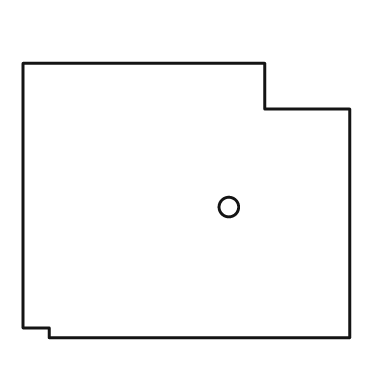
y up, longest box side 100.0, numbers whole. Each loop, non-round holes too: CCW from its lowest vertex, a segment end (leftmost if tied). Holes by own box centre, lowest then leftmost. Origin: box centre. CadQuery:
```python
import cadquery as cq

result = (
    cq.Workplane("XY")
    .moveTo(-42.0, -42.0)
    .lineTo(50.0, -42.0)
    .lineTo(50.0, 28.0)
    .lineTo(24.0, 28.0)
    .lineTo(24.0, 42.0)
    .lineTo(-50.0, 42.0)
    .lineTo(-50.0, -39.0)
    .lineTo(-42.0, -39.0)
    .close()
    .moveTo(13.0, -2.0)
    .circle(3.0)
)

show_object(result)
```